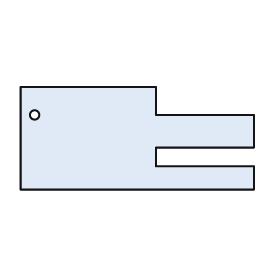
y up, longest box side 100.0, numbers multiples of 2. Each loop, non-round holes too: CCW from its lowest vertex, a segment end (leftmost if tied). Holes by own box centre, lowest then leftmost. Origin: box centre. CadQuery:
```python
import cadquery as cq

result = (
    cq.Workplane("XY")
    .moveTo(-50.0, -22.0)
    .lineTo(50.0, -22.0)
    .lineTo(50.0, -12.0)
    .lineTo(8.0, -12.0)
    .lineTo(8.0, -4.0)
    .lineTo(50.0, -4.0)
    .lineTo(50.0, 10.0)
    .lineTo(8.0, 10.0)
    .lineTo(8.0, 22.0)
    .lineTo(-50.0, 22.0)
    .close()
    .moveTo(-44.0, 10.0)
    .circle(2.0)
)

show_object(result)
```